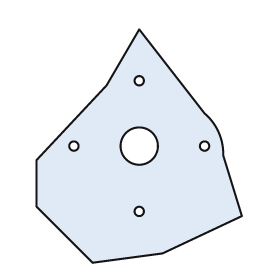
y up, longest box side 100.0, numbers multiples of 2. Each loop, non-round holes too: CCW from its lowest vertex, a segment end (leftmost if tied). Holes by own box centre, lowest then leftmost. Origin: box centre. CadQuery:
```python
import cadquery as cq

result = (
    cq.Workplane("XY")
    .moveTo(-20.0, -50.0)
    .lineTo(10.0, -46.0)
    .lineTo(44.0, -30.0)
    .lineTo(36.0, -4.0)
    .threePointArc((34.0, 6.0), (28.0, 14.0))
    .lineTo(0.0, 50.0)
    .lineTo(-14.0, 26.0)
    .lineTo(-44.0, -6.0)
    .lineTo(-44.0, -26.0)
    .close()
    .moveTo(0.0, -28.0)
    .circle(2.0)
    .moveTo(-28.0, 0.0)
    .circle(2.0)
    .moveTo(0.0, 0.0)
    .circle(8.0)
    .moveTo(28.0, 0.0)
    .circle(2.0)
    .moveTo(0.0, 28.0)
    .circle(2.0)
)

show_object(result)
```